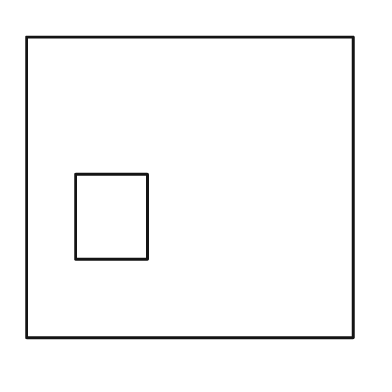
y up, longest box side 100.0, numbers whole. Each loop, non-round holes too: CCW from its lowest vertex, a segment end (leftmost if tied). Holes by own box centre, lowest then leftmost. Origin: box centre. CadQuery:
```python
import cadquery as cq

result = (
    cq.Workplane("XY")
    .moveTo(-50.0, -46.0)
    .lineTo(50.0, -46.0)
    .lineTo(50.0, 46.0)
    .lineTo(-50.0, 46.0)
    .close()
    .moveTo(-35.0, -22.0)
    .lineTo(-13.0, -22.0)
    .lineTo(-13.0, 4.0)
    .lineTo(-35.0, 4.0)
    .close()
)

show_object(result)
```